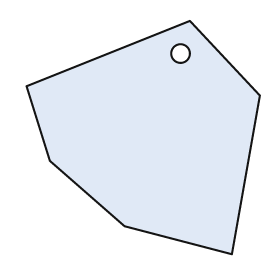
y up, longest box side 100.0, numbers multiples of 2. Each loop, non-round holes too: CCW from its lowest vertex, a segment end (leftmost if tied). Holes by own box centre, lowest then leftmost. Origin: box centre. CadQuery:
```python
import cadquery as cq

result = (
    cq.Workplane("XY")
    .moveTo(38.0, -50.0)
    .lineTo(50.0, 18.0)
    .lineTo(20.0, 50.0)
    .lineTo(-50.0, 22.0)
    .lineTo(-40.0, -10.0)
    .lineTo(-8.0, -38.0)
    .close()
    .moveTo(16.0, 36.0)
    .circle(4.0)
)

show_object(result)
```